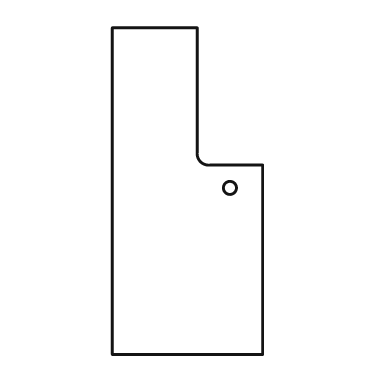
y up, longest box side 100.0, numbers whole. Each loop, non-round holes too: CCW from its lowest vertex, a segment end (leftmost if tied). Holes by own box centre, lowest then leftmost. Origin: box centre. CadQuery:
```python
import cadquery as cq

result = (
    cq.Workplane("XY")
    .moveTo(-23.0, -50.0)
    .lineTo(23.0, -50.0)
    .lineTo(23.0, 8.0)
    .lineTo(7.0, 8.0)
    .threePointArc((4.0, 9.0), (3.0, 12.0))
    .lineTo(3.0, 50.0)
    .lineTo(-23.0, 50.0)
    .close()
    .moveTo(13.0, 1.0)
    .circle(2.0)
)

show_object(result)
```